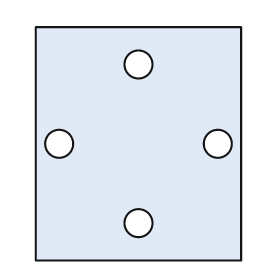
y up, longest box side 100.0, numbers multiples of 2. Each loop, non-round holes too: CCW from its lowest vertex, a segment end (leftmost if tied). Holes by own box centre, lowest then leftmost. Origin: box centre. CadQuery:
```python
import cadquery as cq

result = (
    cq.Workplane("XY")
    .moveTo(-44.0, -50.0)
    .lineTo(44.0, -50.0)
    .lineTo(44.0, 50.0)
    .lineTo(-44.0, 50.0)
    .close()
    .moveTo(0.0, -34.0)
    .circle(6.0)
    .moveTo(-34.0, 0.0)
    .circle(6.0)
    .moveTo(34.0, 0.0)
    .circle(6.0)
    .moveTo(0.0, 34.0)
    .circle(6.0)
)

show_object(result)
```